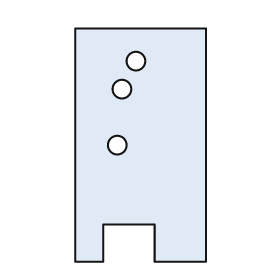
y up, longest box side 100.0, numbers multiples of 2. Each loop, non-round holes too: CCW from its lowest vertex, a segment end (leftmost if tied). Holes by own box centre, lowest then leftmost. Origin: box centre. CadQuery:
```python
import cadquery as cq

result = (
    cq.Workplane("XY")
    .moveTo(-28.0, -50.0)
    .lineTo(-16.0, -50.0)
    .lineTo(-16.0, -34.0)
    .lineTo(6.0, -34.0)
    .lineTo(6.0, -50.0)
    .lineTo(28.0, -50.0)
    .lineTo(28.0, 50.0)
    .lineTo(-28.0, 50.0)
    .close()
    .moveTo(-10.0, 0.0)
    .circle(4.0)
    .moveTo(-8.0, 24.0)
    .circle(4.0)
    .moveTo(-2.0, 36.0)
    .circle(4.0)
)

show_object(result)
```